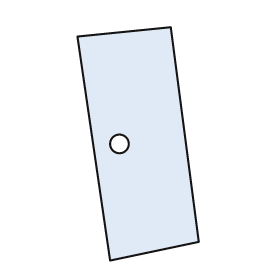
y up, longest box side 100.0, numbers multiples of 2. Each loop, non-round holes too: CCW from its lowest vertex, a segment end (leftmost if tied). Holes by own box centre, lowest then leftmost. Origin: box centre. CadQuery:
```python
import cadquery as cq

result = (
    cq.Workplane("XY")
    .moveTo(-12.0, -50.0)
    .lineTo(26.0, -42.0)
    .lineTo(14.0, 50.0)
    .lineTo(-26.0, 46.0)
    .close()
    .moveTo(-8.0, 0.0)
    .circle(4.0)
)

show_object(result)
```